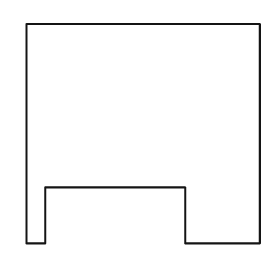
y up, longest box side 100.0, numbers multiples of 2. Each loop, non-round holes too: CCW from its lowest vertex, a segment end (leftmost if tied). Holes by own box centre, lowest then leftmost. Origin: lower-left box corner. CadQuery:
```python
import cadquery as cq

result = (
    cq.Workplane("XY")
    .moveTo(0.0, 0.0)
    .lineTo(8.0, 0.0)
    .lineTo(8.0, 24.0)
    .lineTo(68.0, 24.0)
    .lineTo(68.0, 0.0)
    .lineTo(100.0, 0.0)
    .lineTo(100.0, 94.0)
    .lineTo(0.0, 94.0)
    .close()
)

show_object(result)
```